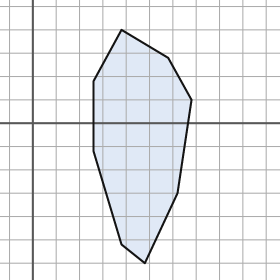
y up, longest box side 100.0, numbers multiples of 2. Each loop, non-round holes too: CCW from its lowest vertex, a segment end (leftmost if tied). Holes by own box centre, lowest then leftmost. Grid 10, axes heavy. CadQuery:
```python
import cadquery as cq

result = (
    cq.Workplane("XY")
    .moveTo(48.0, -60.0)
    .lineTo(62.0, -30.0)
    .lineTo(68.0, 10.0)
    .lineTo(58.0, 28.0)
    .lineTo(38.0, 40.0)
    .lineTo(26.0, 18.0)
    .lineTo(26.0, -12.0)
    .lineTo(38.0, -52.0)
    .close()
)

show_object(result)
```